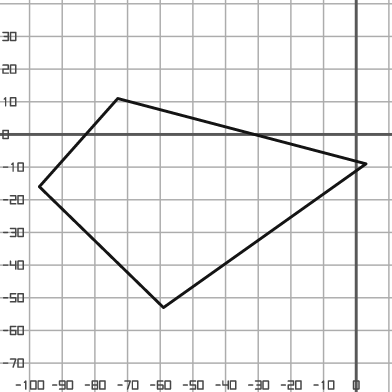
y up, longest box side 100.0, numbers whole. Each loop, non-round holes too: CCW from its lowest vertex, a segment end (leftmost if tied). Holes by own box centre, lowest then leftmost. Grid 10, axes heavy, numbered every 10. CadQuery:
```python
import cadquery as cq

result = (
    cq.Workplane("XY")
    .moveTo(-59.0, -53.0)
    .lineTo(3.0, -9.0)
    .lineTo(-73.0, 11.0)
    .lineTo(-97.0, -16.0)
    .close()
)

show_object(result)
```